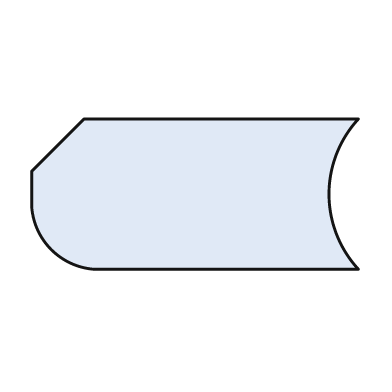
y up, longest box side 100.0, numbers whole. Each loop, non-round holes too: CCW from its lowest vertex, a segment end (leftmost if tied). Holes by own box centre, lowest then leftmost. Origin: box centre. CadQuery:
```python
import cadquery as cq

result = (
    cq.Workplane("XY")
    .moveTo(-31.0, -23.0)
    .lineTo(50.0, -23.0)
    .threePointArc((41.0, 0.0), (50.0, 23.0))
    .lineTo(-34.0, 23.0)
    .lineTo(-50.0, 7.0)
    .lineTo(-50.0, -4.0)
    .threePointArc((-44.0, -17.0), (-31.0, -23.0))
    .close()
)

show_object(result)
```